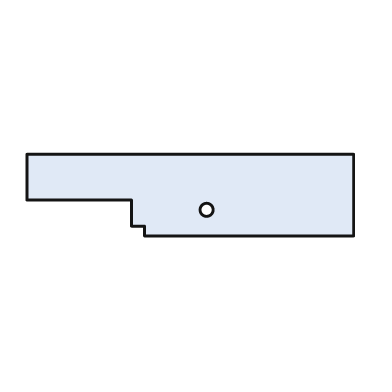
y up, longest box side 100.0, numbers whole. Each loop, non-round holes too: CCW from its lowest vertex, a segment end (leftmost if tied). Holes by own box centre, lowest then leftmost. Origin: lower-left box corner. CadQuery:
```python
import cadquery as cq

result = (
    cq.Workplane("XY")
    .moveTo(36.0, 0.0)
    .lineTo(100.0, 0.0)
    .lineTo(100.0, 25.0)
    .lineTo(0.0, 25.0)
    .lineTo(0.0, 11.0)
    .lineTo(32.0, 11.0)
    .lineTo(32.0, 3.0)
    .lineTo(36.0, 3.0)
    .close()
    .moveTo(55.0, 8.0)
    .circle(2.0)
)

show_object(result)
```